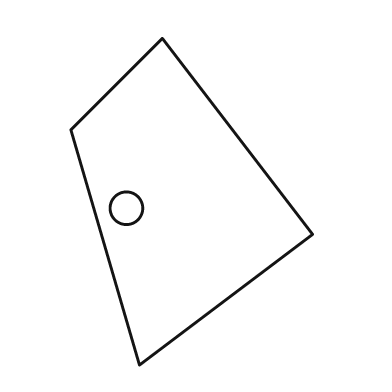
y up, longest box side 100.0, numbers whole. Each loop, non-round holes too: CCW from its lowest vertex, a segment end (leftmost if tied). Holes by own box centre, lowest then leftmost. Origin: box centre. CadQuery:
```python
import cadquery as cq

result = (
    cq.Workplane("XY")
    .moveTo(-16.0, -50.0)
    .lineTo(37.0, -10.0)
    .lineTo(-9.0, 50.0)
    .lineTo(-37.0, 22.0)
    .close()
    .moveTo(-20.0, -2.0)
    .circle(5.0)
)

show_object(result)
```